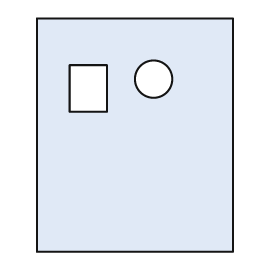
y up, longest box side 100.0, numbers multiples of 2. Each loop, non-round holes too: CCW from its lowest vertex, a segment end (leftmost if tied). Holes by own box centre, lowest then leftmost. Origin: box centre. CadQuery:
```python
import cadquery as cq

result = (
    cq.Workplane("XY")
    .moveTo(-42.0, -50.0)
    .lineTo(42.0, -50.0)
    .lineTo(42.0, 50.0)
    .lineTo(-42.0, 50.0)
    .close()
    .moveTo(-28.0, 10.0)
    .lineTo(-12.0, 10.0)
    .lineTo(-12.0, 30.0)
    .lineTo(-28.0, 30.0)
    .close()
    .moveTo(8.0, 24.0)
    .circle(8.0)
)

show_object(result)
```